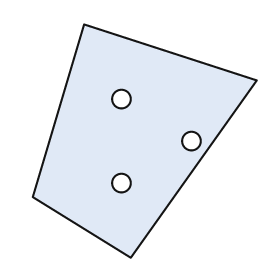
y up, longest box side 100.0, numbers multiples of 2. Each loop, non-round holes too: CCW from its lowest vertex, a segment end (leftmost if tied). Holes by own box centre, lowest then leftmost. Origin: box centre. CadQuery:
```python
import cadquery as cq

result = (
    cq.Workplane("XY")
    .moveTo(-6.0, -50.0)
    .lineTo(48.0, 26.0)
    .lineTo(-26.0, 50.0)
    .lineTo(-48.0, -24.0)
    .close()
    .moveTo(-10.0, -18.0)
    .circle(4.0)
    .moveTo(20.0, 0.0)
    .circle(4.0)
    .moveTo(-10.0, 18.0)
    .circle(4.0)
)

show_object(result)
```